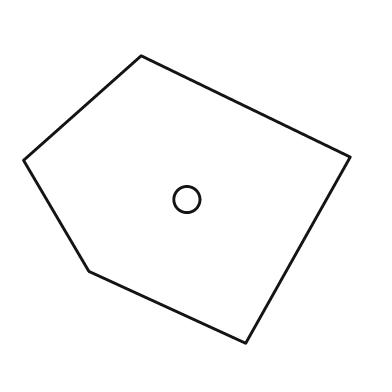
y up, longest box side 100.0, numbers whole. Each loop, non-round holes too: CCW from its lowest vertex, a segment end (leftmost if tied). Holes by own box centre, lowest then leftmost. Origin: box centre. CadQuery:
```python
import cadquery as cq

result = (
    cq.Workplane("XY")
    .moveTo(18.0, -44.0)
    .lineTo(50.0, 13.0)
    .lineTo(-14.0, 44.0)
    .lineTo(-50.0, 12.0)
    .lineTo(-30.0, -22.0)
    .close()
    .moveTo(0.0, 0.0)
    .circle(4.0)
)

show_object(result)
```